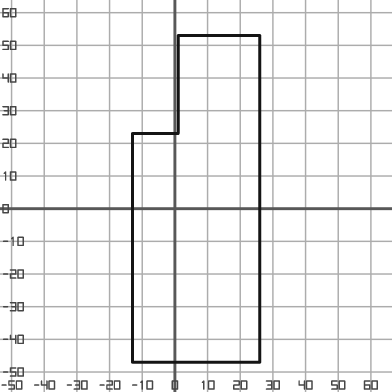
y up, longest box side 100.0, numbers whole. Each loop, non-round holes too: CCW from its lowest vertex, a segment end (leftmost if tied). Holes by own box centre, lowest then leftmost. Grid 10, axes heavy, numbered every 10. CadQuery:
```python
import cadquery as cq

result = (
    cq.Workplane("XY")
    .moveTo(-13.0, -47.0)
    .lineTo(26.0, -47.0)
    .lineTo(26.0, 53.0)
    .lineTo(1.0, 53.0)
    .lineTo(1.0, 23.0)
    .lineTo(-13.0, 23.0)
    .close()
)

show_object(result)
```